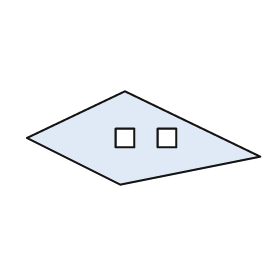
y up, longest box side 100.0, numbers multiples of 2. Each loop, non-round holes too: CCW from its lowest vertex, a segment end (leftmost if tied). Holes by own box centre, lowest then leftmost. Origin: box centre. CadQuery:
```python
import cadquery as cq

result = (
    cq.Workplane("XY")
    .moveTo(-10.0, -20.0)
    .lineTo(50.0, -8.0)
    .lineTo(-8.0, 20.0)
    .lineTo(-50.0, 0.0)
    .close()
    .moveTo(-12.0, -4.0)
    .lineTo(-4.0, -4.0)
    .lineTo(-4.0, 4.0)
    .lineTo(-12.0, 4.0)
    .close()
    .moveTo(6.0, -4.0)
    .lineTo(14.0, -4.0)
    .lineTo(14.0, 4.0)
    .lineTo(6.0, 4.0)
    .close()
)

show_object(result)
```